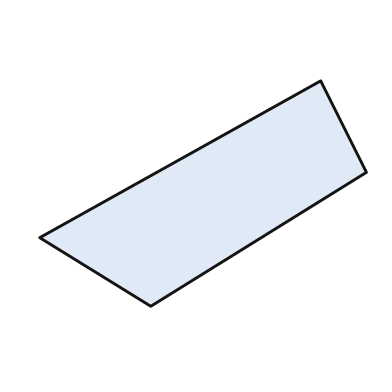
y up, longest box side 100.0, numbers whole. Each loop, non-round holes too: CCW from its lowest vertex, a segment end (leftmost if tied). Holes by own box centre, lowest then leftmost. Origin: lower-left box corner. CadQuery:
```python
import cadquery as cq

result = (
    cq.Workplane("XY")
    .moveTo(34.0, 0.0)
    .lineTo(100.0, 41.0)
    .lineTo(86.0, 69.0)
    .lineTo(0.0, 21.0)
    .close()
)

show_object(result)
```